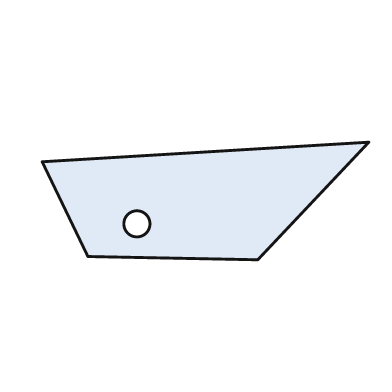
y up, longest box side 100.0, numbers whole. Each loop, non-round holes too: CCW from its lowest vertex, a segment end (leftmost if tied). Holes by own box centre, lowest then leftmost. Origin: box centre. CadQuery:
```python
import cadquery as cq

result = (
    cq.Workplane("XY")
    .moveTo(16.0, -18.0)
    .lineTo(50.0, 18.0)
    .lineTo(-50.0, 12.0)
    .lineTo(-36.0, -17.0)
    .close()
    .moveTo(-21.0, -7.0)
    .circle(4.0)
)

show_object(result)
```